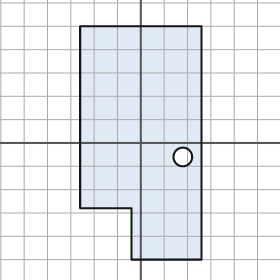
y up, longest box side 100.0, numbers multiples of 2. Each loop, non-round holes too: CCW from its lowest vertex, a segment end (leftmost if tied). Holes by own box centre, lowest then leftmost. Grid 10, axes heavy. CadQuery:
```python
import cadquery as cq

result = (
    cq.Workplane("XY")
    .moveTo(-4.0, -50.0)
    .lineTo(26.0, -50.0)
    .lineTo(26.0, 50.0)
    .lineTo(-26.0, 50.0)
    .lineTo(-26.0, -28.0)
    .lineTo(-4.0, -28.0)
    .close()
    .moveTo(18.0, -6.0)
    .circle(4.0)
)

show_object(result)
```